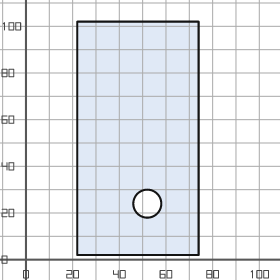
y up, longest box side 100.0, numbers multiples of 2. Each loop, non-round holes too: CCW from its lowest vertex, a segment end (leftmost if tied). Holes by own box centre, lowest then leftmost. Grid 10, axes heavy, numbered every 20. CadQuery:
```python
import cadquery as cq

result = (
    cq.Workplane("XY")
    .moveTo(22.0, 2.0)
    .lineTo(74.0, 2.0)
    .lineTo(74.0, 102.0)
    .lineTo(22.0, 102.0)
    .close()
    .moveTo(52.0, 24.0)
    .circle(6.0)
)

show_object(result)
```